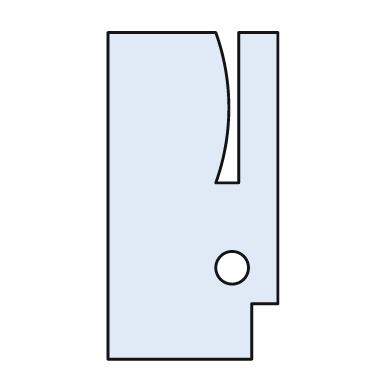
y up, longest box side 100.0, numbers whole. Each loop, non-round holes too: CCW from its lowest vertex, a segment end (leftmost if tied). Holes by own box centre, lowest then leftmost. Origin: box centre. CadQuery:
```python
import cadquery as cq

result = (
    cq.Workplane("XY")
    .moveTo(-26.0, -50.0)
    .lineTo(18.0, -50.0)
    .lineTo(18.0, -33.0)
    .lineTo(26.0, -33.0)
    .lineTo(26.0, 50.0)
    .lineTo(14.0, 50.0)
    .lineTo(14.0, 4.0)
    .lineTo(7.0, 4.0)
    .threePointArc((11.0, 27.0), (7.0, 50.0))
    .lineTo(-26.0, 50.0)
    .close()
    .moveTo(12.0, -22.0)
    .circle(5.0)
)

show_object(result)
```